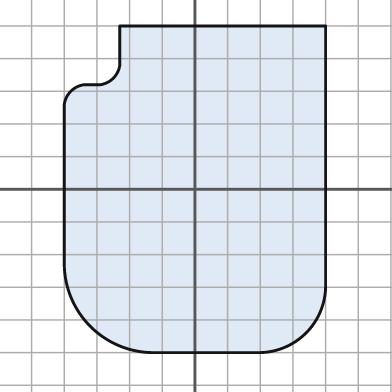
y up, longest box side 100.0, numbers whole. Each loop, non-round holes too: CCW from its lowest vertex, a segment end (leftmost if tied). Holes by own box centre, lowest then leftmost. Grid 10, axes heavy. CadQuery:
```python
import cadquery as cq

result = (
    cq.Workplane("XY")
    .moveTo(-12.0, -50.0)
    .lineTo(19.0, -50.0)
    .threePointArc((34.0, -44.0), (40.0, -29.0))
    .lineTo(40.0, 50.0)
    .lineTo(-23.0, 50.0)
    .lineTo(-23.0, 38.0)
    .threePointArc((-25.0, 34.0), (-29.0, 32.0))
    .lineTo(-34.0, 32.0)
    .threePointArc((-38.0, 30.0), (-40.0, 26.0))
    .lineTo(-40.0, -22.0)
    .threePointArc((-32.0, -42.0), (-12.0, -50.0))
    .close()
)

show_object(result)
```